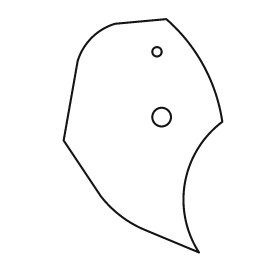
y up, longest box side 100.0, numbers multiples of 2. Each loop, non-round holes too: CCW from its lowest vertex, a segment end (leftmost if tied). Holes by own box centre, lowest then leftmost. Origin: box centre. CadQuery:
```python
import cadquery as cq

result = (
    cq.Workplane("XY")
    .moveTo(24.0, -50.0)
    .threePointArc((18.0, -20.0), (34.0, 6.0))
    .threePointArc((26.0, 30.0), (10.0, 50.0))
    .lineTo(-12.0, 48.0)
    .threePointArc((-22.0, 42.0), (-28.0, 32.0))
    .lineTo(-34.0, -2.0)
    .lineTo(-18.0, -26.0)
    .threePointArc((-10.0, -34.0), (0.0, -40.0))
    .close()
    .moveTo(8.0, 8.0)
    .circle(4.0)
    .moveTo(6.0, 36.0)
    .circle(2.0)
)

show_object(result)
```